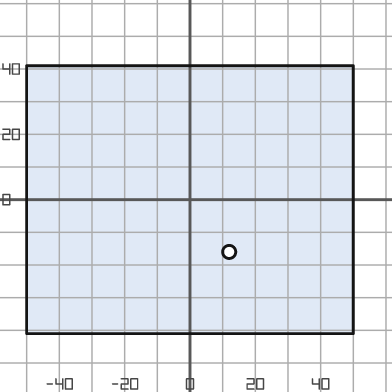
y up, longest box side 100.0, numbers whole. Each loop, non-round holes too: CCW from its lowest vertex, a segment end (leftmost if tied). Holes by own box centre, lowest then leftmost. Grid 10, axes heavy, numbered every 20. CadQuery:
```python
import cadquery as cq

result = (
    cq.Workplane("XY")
    .moveTo(-50.0, -41.0)
    .lineTo(50.0, -41.0)
    .lineTo(50.0, 41.0)
    .lineTo(-50.0, 41.0)
    .close()
    .moveTo(12.0, -16.0)
    .circle(2.0)
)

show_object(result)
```